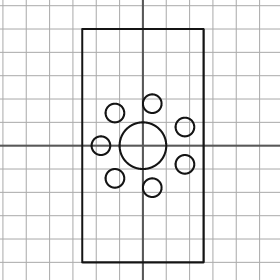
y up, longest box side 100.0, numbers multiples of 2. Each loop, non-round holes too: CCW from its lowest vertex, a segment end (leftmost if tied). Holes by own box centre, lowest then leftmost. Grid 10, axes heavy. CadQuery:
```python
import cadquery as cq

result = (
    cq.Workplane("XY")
    .moveTo(-26.0, -50.0)
    .lineTo(26.0, -50.0)
    .lineTo(26.0, 50.0)
    .lineTo(-26.0, 50.0)
    .close()
    .moveTo(4.0, -18.0)
    .circle(4.0)
    .moveTo(-12.0, -14.0)
    .circle(4.0)
    .moveTo(18.0, -8.0)
    .circle(4.0)
    .moveTo(-18.0, 0.0)
    .circle(4.0)
    .moveTo(0.0, 0.0)
    .circle(10.0)
    .moveTo(18.0, 8.0)
    .circle(4.0)
    .moveTo(-12.0, 14.0)
    .circle(4.0)
    .moveTo(4.0, 18.0)
    .circle(4.0)
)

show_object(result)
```